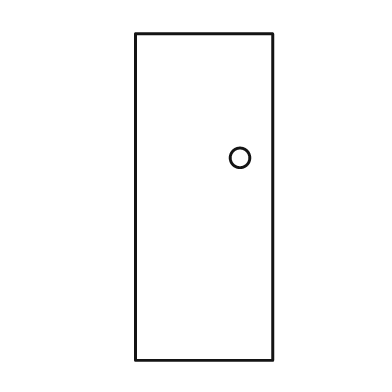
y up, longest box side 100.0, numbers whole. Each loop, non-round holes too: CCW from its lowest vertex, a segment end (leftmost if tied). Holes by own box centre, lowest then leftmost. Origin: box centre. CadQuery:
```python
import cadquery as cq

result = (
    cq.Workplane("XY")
    .moveTo(-21.0, -50.0)
    .lineTo(21.0, -50.0)
    .lineTo(21.0, 50.0)
    .lineTo(-21.0, 50.0)
    .close()
    .moveTo(11.0, 12.0)
    .circle(3.0)
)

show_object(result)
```